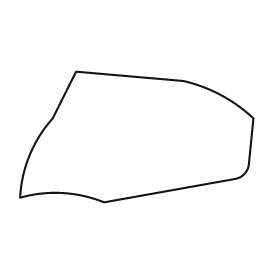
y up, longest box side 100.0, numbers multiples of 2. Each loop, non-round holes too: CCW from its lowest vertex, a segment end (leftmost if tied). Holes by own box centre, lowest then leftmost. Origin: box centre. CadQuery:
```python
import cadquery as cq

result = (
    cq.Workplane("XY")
    .moveTo(-14.0, -28.0)
    .lineTo(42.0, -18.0)
    .threePointArc((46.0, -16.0), (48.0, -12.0))
    .lineTo(50.0, 8.0)
    .threePointArc((36.0, 18.0), (20.0, 24.0))
    .lineTo(-26.0, 28.0)
    .lineTo(-36.0, 8.0)
    .threePointArc((-46.0, -8.0), (-50.0, -26.0))
    .threePointArc((-32.0, -24.0), (-14.0, -28.0))
    .close()
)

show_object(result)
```